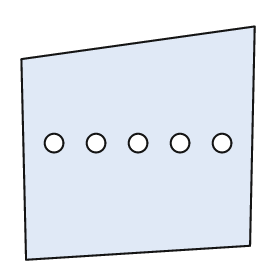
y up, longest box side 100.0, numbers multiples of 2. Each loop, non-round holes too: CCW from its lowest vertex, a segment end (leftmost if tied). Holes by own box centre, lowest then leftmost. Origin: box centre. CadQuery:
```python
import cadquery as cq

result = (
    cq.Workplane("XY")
    .moveTo(-48.0, -50.0)
    .lineTo(48.0, -44.0)
    .lineTo(50.0, 50.0)
    .lineTo(-50.0, 36.0)
    .close()
    .moveTo(-36.0, 0.0)
    .circle(4.0)
    .moveTo(-18.0, 0.0)
    .circle(4.0)
    .moveTo(0.0, 0.0)
    .circle(4.0)
    .moveTo(18.0, 0.0)
    .circle(4.0)
    .moveTo(36.0, 0.0)
    .circle(4.0)
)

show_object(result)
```